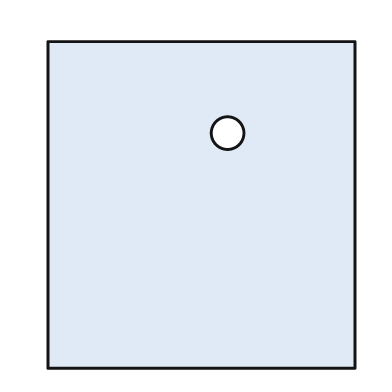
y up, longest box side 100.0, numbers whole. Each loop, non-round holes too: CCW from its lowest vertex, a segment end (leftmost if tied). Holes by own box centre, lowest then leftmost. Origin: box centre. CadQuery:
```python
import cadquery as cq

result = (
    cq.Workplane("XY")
    .moveTo(-47.0, -50.0)
    .lineTo(47.0, -50.0)
    .lineTo(47.0, 50.0)
    .lineTo(-47.0, 50.0)
    .close()
    .moveTo(8.0, 22.0)
    .circle(5.0)
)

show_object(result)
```